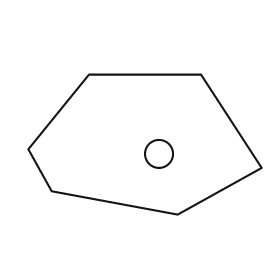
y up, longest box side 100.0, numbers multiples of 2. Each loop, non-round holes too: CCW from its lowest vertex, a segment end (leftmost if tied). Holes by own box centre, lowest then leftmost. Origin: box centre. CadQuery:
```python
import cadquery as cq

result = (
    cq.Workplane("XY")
    .moveTo(14.0, -30.0)
    .lineTo(50.0, -10.0)
    .lineTo(24.0, 30.0)
    .lineTo(-24.0, 30.0)
    .lineTo(-50.0, -2.0)
    .lineTo(-40.0, -20.0)
    .close()
    .moveTo(6.0, -4.0)
    .circle(6.0)
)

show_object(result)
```